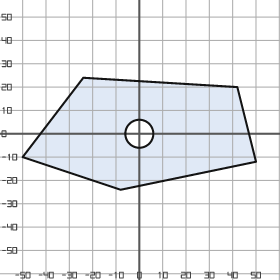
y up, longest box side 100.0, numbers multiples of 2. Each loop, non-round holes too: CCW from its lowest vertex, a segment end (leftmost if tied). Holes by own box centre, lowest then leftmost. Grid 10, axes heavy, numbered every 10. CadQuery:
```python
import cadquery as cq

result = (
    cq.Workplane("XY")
    .moveTo(-8.0, -24.0)
    .lineTo(50.0, -12.0)
    .lineTo(42.0, 20.0)
    .lineTo(-24.0, 24.0)
    .lineTo(-50.0, -10.0)
    .close()
    .moveTo(0.0, 0.0)
    .circle(6.0)
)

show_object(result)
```